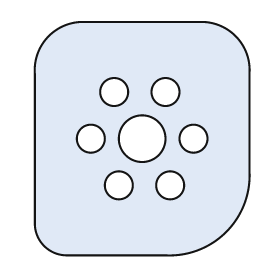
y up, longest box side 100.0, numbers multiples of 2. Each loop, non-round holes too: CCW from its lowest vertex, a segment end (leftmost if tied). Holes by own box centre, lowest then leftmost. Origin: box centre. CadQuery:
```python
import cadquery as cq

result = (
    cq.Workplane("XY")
    .moveTo(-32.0, -50.0)
    .lineTo(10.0, -50.0)
    .threePointArc((36.0, -40.0), (46.0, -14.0))
    .lineTo(46.0, 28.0)
    .threePointArc((40.0, 44.0), (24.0, 50.0))
    .lineTo(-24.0, 50.0)
    .threePointArc((-40.0, 44.0), (-46.0, 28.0))
    .lineTo(-46.0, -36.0)
    .threePointArc((-42.0, -46.0), (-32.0, -50.0))
    .close()
    .moveTo(-10.0, -20.0)
    .circle(6.0)
    .moveTo(12.0, -20.0)
    .circle(6.0)
    .moveTo(-22.0, 0.0)
    .circle(6.0)
    .moveTo(0.0, 0.0)
    .circle(10.0)
    .moveTo(22.0, 0.0)
    .circle(6.0)
    .moveTo(-12.0, 20.0)
    .circle(6.0)
    .moveTo(10.0, 20.0)
    .circle(6.0)
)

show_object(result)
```